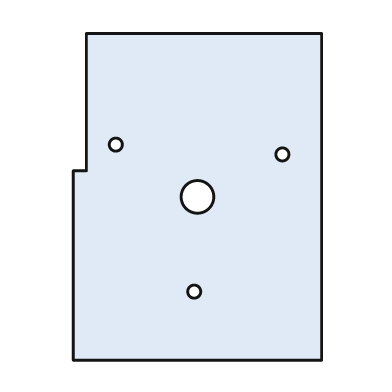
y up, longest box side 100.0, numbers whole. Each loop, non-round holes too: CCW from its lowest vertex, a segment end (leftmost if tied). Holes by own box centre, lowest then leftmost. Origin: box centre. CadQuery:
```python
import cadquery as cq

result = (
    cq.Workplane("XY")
    .moveTo(-38.0, -50.0)
    .lineTo(38.0, -50.0)
    .lineTo(38.0, 50.0)
    .lineTo(-34.0, 50.0)
    .lineTo(-34.0, 8.0)
    .lineTo(-38.0, 8.0)
    .close()
    .moveTo(-1.0, -29.0)
    .circle(2.0)
    .moveTo(0.0, 0.0)
    .circle(5.0)
    .moveTo(26.0, 13.0)
    .circle(2.0)
    .moveTo(-25.0, 16.0)
    .circle(2.0)
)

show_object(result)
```